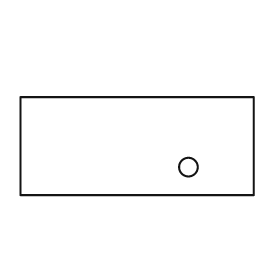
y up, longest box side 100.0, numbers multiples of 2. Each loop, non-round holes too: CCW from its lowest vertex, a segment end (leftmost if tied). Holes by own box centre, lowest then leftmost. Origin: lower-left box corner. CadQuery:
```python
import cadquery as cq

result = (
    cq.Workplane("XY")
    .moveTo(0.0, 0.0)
    .lineTo(100.0, 0.0)
    .lineTo(100.0, 42.0)
    .lineTo(0.0, 42.0)
    .close()
    .moveTo(72.0, 12.0)
    .circle(4.0)
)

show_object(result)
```